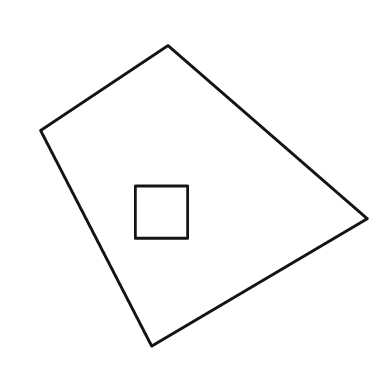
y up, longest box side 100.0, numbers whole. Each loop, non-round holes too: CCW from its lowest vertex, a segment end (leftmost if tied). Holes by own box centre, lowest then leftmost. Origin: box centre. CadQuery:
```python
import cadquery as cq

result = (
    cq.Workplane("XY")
    .moveTo(-16.0, -46.0)
    .lineTo(50.0, -7.0)
    .lineTo(-11.0, 46.0)
    .lineTo(-50.0, 20.0)
    .close()
    .moveTo(-21.0, -13.0)
    .lineTo(-5.0, -13.0)
    .lineTo(-5.0, 3.0)
    .lineTo(-21.0, 3.0)
    .close()
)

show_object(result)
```